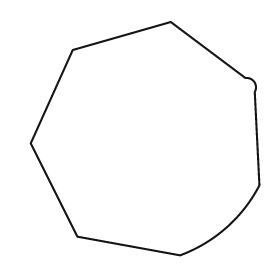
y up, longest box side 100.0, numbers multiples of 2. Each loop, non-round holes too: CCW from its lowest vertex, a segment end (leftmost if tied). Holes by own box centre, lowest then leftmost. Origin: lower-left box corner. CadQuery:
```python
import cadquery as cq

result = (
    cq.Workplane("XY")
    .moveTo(64.0, 0.0)
    .threePointArc((84.0, 12.0), (98.0, 30.0))
    .lineTo(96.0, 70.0)
    .threePointArc((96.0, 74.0), (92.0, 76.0))
    .lineTo(60.0, 100.0)
    .lineTo(18.0, 88.0)
    .lineTo(0.0, 48.0)
    .lineTo(20.0, 8.0)
    .close()
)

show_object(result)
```